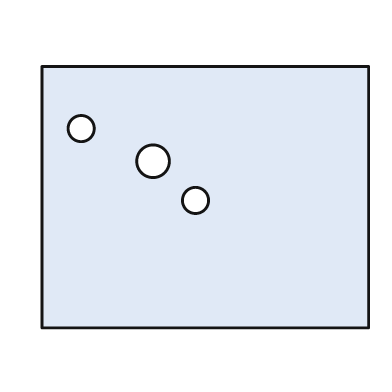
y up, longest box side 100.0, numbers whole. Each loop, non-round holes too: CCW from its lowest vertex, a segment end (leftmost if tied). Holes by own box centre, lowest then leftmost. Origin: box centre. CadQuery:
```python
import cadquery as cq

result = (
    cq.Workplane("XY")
    .moveTo(-50.0, -40.0)
    .lineTo(50.0, -40.0)
    .lineTo(50.0, 40.0)
    .lineTo(-50.0, 40.0)
    .close()
    .moveTo(-3.0, -1.0)
    .circle(4.0)
    .moveTo(-16.0, 11.0)
    .circle(5.0)
    .moveTo(-38.0, 21.0)
    .circle(4.0)
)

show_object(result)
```